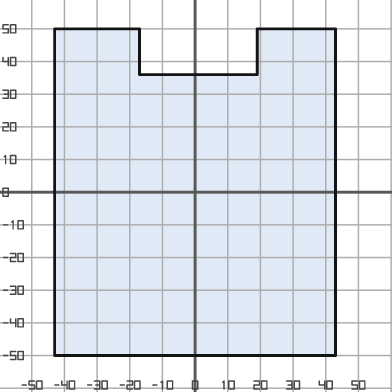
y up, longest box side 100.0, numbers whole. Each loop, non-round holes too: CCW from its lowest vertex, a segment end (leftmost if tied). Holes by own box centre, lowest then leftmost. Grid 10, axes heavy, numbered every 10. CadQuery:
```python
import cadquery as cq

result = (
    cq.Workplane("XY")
    .moveTo(-43.0, -50.0)
    .lineTo(43.0, -50.0)
    .lineTo(43.0, 50.0)
    .lineTo(19.0, 50.0)
    .lineTo(19.0, 36.0)
    .lineTo(-17.0, 36.0)
    .lineTo(-17.0, 50.0)
    .lineTo(-43.0, 50.0)
    .close()
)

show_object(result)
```